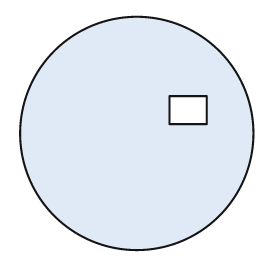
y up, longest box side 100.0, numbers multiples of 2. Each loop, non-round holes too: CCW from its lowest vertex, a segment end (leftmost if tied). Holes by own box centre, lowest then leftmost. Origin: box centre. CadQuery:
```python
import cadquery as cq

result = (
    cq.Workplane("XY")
    .moveTo(0.0, 0.0)
    .circle(50.0)
    .moveTo(14.0, 4.0)
    .lineTo(30.0, 4.0)
    .lineTo(30.0, 16.0)
    .lineTo(14.0, 16.0)
    .close()
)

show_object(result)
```